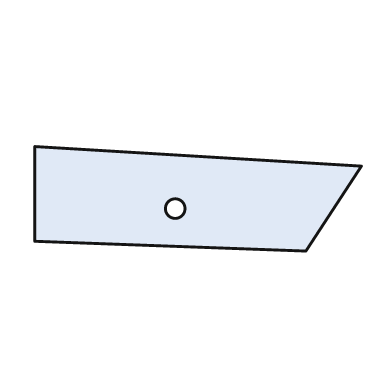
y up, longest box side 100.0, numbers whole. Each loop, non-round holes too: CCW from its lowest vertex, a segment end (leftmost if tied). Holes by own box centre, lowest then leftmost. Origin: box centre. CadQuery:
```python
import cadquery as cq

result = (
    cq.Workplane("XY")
    .moveTo(33.0, -16.0)
    .lineTo(50.0, 10.0)
    .lineTo(-50.0, 16.0)
    .lineTo(-50.0, -13.0)
    .close()
    .moveTo(-7.0, -3.0)
    .circle(3.0)
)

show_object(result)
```